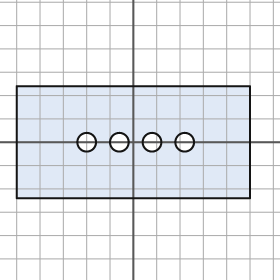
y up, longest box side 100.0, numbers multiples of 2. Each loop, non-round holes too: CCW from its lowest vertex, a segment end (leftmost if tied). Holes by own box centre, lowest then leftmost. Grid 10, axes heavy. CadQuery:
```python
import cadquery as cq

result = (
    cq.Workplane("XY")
    .moveTo(-50.0, -24.0)
    .lineTo(50.0, -24.0)
    .lineTo(50.0, 24.0)
    .lineTo(-50.0, 24.0)
    .close()
    .moveTo(-20.0, 0.0)
    .circle(4.0)
    .moveTo(-6.0, 0.0)
    .circle(4.0)
    .moveTo(8.0, 0.0)
    .circle(4.0)
    .moveTo(22.0, 0.0)
    .circle(4.0)
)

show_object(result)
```